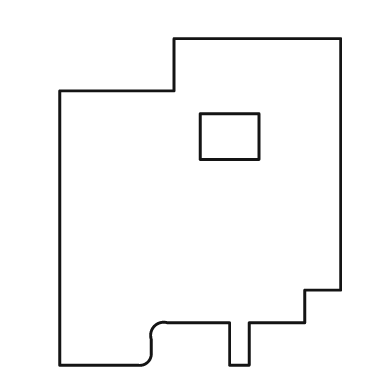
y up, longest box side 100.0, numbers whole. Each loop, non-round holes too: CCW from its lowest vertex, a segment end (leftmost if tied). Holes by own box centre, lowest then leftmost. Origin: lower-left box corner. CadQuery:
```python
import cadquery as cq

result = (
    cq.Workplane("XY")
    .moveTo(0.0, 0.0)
    .lineTo(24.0, 0.0)
    .threePointArc((27.0, 1.0), (28.0, 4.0))
    .lineTo(28.0, 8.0)
    .threePointArc((29.0, 12.0), (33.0, 13.0))
    .lineTo(52.0, 13.0)
    .lineTo(52.0, 0.0)
    .lineTo(58.0, 0.0)
    .lineTo(58.0, 13.0)
    .lineTo(75.0, 13.0)
    .lineTo(75.0, 23.0)
    .lineTo(86.0, 23.0)
    .lineTo(86.0, 100.0)
    .lineTo(35.0, 100.0)
    .lineTo(35.0, 84.0)
    .lineTo(0.0, 84.0)
    .close()
    .moveTo(43.0, 63.0)
    .lineTo(61.0, 63.0)
    .lineTo(61.0, 77.0)
    .lineTo(43.0, 77.0)
    .close()
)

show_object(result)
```